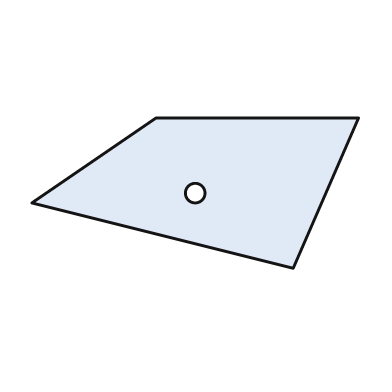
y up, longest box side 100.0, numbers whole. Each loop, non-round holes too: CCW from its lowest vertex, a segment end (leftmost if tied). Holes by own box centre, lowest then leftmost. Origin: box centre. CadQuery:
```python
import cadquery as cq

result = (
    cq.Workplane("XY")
    .moveTo(30.0, -23.0)
    .lineTo(50.0, 23.0)
    .lineTo(-12.0, 23.0)
    .lineTo(-50.0, -3.0)
    .close()
    .moveTo(0.0, 0.0)
    .circle(3.0)
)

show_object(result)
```